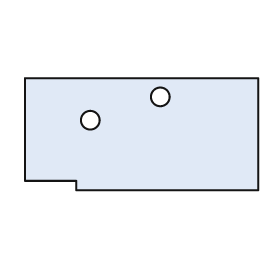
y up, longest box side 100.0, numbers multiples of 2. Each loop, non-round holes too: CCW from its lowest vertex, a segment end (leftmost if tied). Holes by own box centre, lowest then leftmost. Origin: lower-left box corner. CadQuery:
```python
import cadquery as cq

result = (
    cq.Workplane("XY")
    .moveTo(22.0, 0.0)
    .lineTo(100.0, 0.0)
    .lineTo(100.0, 48.0)
    .lineTo(0.0, 48.0)
    .lineTo(0.0, 4.0)
    .lineTo(22.0, 4.0)
    .close()
    .moveTo(28.0, 30.0)
    .circle(4.0)
    .moveTo(58.0, 40.0)
    .circle(4.0)
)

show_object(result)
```